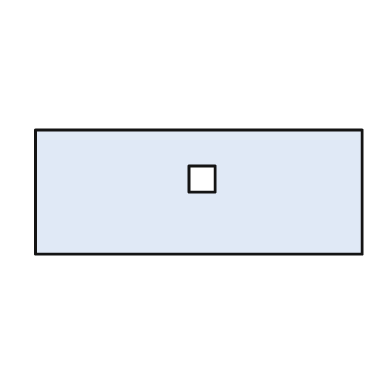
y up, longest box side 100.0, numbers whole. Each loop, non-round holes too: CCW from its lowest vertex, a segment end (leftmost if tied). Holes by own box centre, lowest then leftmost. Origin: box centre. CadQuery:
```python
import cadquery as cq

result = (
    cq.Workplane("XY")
    .moveTo(-50.0, -19.0)
    .lineTo(50.0, -19.0)
    .lineTo(50.0, 19.0)
    .lineTo(-50.0, 19.0)
    .close()
    .moveTo(-3.0, 0.0)
    .lineTo(5.0, 0.0)
    .lineTo(5.0, 8.0)
    .lineTo(-3.0, 8.0)
    .close()
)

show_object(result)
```